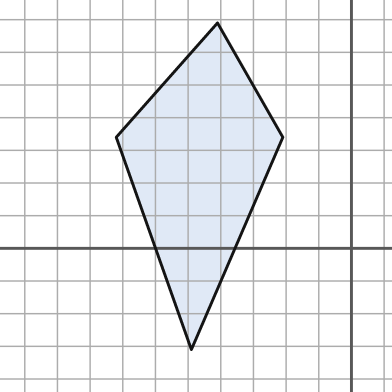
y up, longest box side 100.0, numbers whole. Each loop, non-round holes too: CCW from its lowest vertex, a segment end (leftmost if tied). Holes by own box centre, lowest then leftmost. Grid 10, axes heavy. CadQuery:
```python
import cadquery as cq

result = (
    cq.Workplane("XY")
    .moveTo(-49.0, -31.0)
    .lineTo(-21.0, 34.0)
    .lineTo(-41.0, 69.0)
    .lineTo(-72.0, 34.0)
    .close()
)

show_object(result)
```